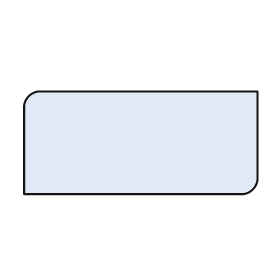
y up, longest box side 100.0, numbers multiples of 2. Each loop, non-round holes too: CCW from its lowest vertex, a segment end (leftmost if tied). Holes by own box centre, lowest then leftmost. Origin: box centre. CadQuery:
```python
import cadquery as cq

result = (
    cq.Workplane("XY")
    .moveTo(-50.0, -22.0)
    .lineTo(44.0, -22.0)
    .threePointArc((48.0, -20.0), (50.0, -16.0))
    .lineTo(50.0, 22.0)
    .lineTo(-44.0, 22.0)
    .threePointArc((-48.0, 20.0), (-50.0, 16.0))
    .close()
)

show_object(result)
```